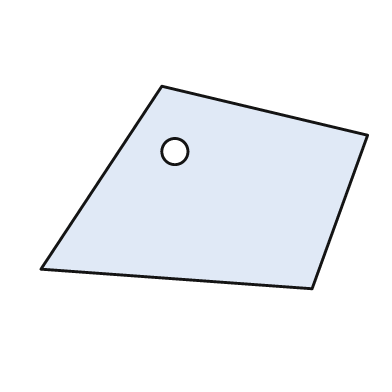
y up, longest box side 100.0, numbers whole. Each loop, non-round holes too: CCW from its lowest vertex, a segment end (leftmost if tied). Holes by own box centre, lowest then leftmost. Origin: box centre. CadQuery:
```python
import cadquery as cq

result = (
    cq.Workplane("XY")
    .moveTo(33.0, -31.0)
    .lineTo(50.0, 16.0)
    .lineTo(-13.0, 31.0)
    .lineTo(-50.0, -25.0)
    .close()
    .moveTo(-9.0, 11.0)
    .circle(4.0)
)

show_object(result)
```